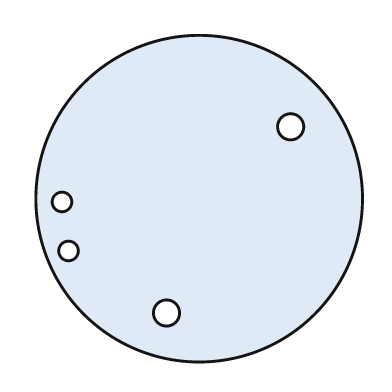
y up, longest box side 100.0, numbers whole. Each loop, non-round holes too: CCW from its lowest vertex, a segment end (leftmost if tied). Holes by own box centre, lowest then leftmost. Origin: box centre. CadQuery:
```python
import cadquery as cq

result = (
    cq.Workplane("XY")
    .moveTo(0.0, 0.0)
    .circle(50.0)
    .moveTo(-10.0, -35.0)
    .circle(4.0)
    .moveTo(-40.0, -16.0)
    .circle(3.0)
    .moveTo(-42.0, -1.0)
    .circle(3.0)
    .moveTo(28.0, 22.0)
    .circle(4.0)
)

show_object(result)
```